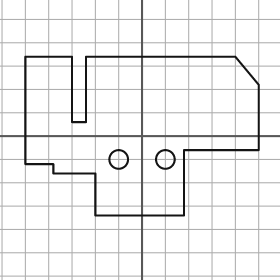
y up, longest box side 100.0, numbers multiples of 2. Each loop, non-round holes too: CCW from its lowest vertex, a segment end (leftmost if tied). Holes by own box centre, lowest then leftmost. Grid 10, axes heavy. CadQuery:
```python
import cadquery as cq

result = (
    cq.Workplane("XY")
    .moveTo(-20.0, -34.0)
    .lineTo(18.0, -34.0)
    .lineTo(18.0, -6.0)
    .lineTo(50.0, -6.0)
    .lineTo(50.0, 22.0)
    .lineTo(40.0, 34.0)
    .lineTo(-24.0, 34.0)
    .lineTo(-24.0, 6.0)
    .lineTo(-30.0, 6.0)
    .lineTo(-30.0, 34.0)
    .lineTo(-50.0, 34.0)
    .lineTo(-50.0, -12.0)
    .lineTo(-38.0, -12.0)
    .lineTo(-38.0, -16.0)
    .lineTo(-20.0, -16.0)
    .close()
    .moveTo(-10.0, -10.0)
    .circle(4.0)
    .moveTo(10.0, -10.0)
    .circle(4.0)
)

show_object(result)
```